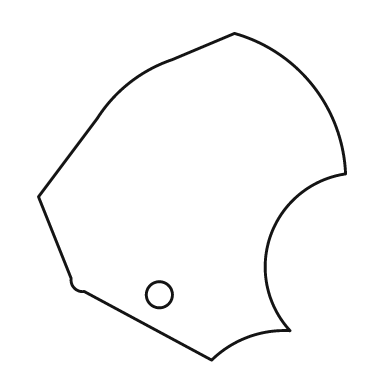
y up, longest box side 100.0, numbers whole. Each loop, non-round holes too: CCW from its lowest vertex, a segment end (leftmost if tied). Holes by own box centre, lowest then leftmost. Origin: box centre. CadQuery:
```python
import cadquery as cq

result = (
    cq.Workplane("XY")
    .moveTo(6.0, -50.0)
    .threePointArc((17.0, -43.0), (30.0, -41.0))
    .threePointArc((24.0, -12.0), (47.0, 7.0))
    .threePointArc((37.0, 34.0), (13.0, 50.0))
    .lineTo(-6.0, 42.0)
    .threePointArc((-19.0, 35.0), (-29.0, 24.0))
    .lineTo(-47.0, 0.0)
    .lineTo(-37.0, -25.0)
    .threePointArc((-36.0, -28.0), (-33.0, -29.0))
    .close()
    .moveTo(-10.0, -30.0)
    .circle(4.0)
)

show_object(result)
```